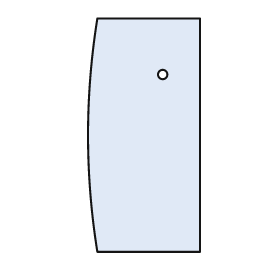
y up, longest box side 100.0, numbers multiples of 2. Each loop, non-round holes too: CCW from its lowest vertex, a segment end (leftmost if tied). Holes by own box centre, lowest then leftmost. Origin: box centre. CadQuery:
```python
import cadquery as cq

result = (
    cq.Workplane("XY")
    .moveTo(-20.0, -50.0)
    .lineTo(24.0, -50.0)
    .lineTo(24.0, 50.0)
    .lineTo(-20.0, 50.0)
    .threePointArc((-24.0, 0.0), (-20.0, -50.0))
    .close()
    .moveTo(8.0, 26.0)
    .circle(2.0)
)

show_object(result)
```